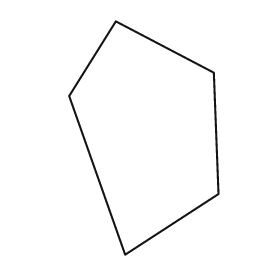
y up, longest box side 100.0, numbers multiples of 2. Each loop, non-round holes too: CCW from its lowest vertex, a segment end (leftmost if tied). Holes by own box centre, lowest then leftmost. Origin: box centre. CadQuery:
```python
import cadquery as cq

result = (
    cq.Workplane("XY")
    .moveTo(-8.0, -50.0)
    .lineTo(32.0, -24.0)
    .lineTo(30.0, 28.0)
    .lineTo(-12.0, 50.0)
    .lineTo(-32.0, 18.0)
    .close()
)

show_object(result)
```